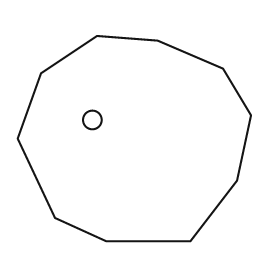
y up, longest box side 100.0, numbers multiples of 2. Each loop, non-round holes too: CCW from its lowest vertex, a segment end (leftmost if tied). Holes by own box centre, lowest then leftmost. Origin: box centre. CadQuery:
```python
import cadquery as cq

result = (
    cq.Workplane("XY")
    .moveTo(-12.0, -44.0)
    .lineTo(24.0, -44.0)
    .lineTo(44.0, -18.0)
    .lineTo(50.0, 10.0)
    .lineTo(38.0, 30.0)
    .lineTo(10.0, 42.0)
    .lineTo(-16.0, 44.0)
    .lineTo(-40.0, 28.0)
    .lineTo(-50.0, 0.0)
    .lineTo(-34.0, -34.0)
    .close()
    .moveTo(-18.0, 8.0)
    .circle(4.0)
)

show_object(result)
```